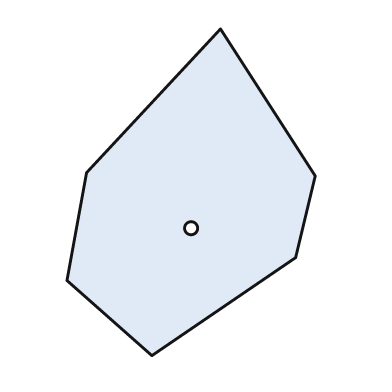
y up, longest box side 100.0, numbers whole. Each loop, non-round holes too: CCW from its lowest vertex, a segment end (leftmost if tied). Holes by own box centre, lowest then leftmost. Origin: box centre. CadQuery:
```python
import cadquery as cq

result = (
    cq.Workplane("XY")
    .moveTo(-12.0, -50.0)
    .lineTo(32.0, -20.0)
    .lineTo(38.0, 5.0)
    .lineTo(9.0, 50.0)
    .lineTo(-32.0, 6.0)
    .lineTo(-38.0, -27.0)
    .close()
    .moveTo(0.0, -11.0)
    .circle(2.0)
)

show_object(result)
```